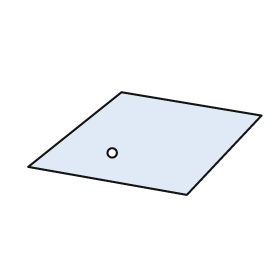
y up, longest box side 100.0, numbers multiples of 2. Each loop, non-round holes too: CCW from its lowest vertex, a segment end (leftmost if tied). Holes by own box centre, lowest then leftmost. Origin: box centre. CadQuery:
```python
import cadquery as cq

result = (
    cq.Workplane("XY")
    .moveTo(18.0, -22.0)
    .lineTo(50.0, 12.0)
    .lineTo(-10.0, 22.0)
    .lineTo(-50.0, -10.0)
    .close()
    .moveTo(-14.0, -4.0)
    .circle(2.0)
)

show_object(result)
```